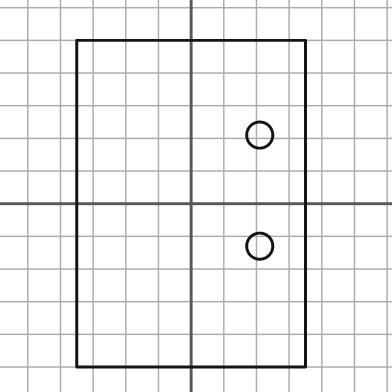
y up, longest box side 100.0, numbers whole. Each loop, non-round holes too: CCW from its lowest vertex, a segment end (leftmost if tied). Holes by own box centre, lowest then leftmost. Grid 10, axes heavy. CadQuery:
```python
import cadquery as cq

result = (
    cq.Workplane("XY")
    .moveTo(-35.0, -50.0)
    .lineTo(35.0, -50.0)
    .lineTo(35.0, 50.0)
    .lineTo(-35.0, 50.0)
    .close()
    .moveTo(21.0, -13.0)
    .circle(4.0)
    .moveTo(21.0, 21.0)
    .circle(4.0)
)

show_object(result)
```